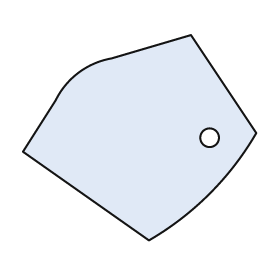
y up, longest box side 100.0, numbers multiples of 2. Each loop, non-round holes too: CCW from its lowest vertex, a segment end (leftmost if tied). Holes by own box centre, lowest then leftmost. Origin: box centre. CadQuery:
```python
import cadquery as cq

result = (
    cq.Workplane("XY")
    .moveTo(4.0, -44.0)
    .threePointArc((30.0, -24.0), (50.0, 2.0))
    .lineTo(22.0, 44.0)
    .lineTo(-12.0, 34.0)
    .threePointArc((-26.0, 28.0), (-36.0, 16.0))
    .lineTo(-50.0, -6.0)
    .close()
    .moveTo(30.0, 0.0)
    .circle(4.0)
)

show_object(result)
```